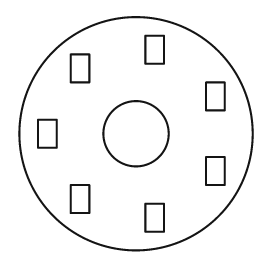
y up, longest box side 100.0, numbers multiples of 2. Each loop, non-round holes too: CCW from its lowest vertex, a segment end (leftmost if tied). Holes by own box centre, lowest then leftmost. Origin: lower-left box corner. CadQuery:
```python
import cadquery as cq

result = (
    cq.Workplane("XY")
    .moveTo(50.0, 50.0)
    .circle(50.0)
    .moveTo(54.0, 8.0)
    .lineTo(62.0, 8.0)
    .lineTo(62.0, 20.0)
    .lineTo(54.0, 20.0)
    .close()
    .moveTo(22.0, 16.0)
    .lineTo(30.0, 16.0)
    .lineTo(30.0, 28.0)
    .lineTo(22.0, 28.0)
    .close()
    .moveTo(80.0, 28.0)
    .lineTo(88.0, 28.0)
    .lineTo(88.0, 40.0)
    .lineTo(80.0, 40.0)
    .close()
    .moveTo(8.0, 44.0)
    .lineTo(16.0, 44.0)
    .lineTo(16.0, 56.0)
    .lineTo(8.0, 56.0)
    .close()
    .moveTo(50.0, 50.0)
    .circle(14.0)
    .moveTo(80.0, 60.0)
    .lineTo(88.0, 60.0)
    .lineTo(88.0, 72.0)
    .lineTo(80.0, 72.0)
    .close()
    .moveTo(22.0, 72.0)
    .lineTo(30.0, 72.0)
    .lineTo(30.0, 84.0)
    .lineTo(22.0, 84.0)
    .close()
    .moveTo(54.0, 80.0)
    .lineTo(62.0, 80.0)
    .lineTo(62.0, 92.0)
    .lineTo(54.0, 92.0)
    .close()
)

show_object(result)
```